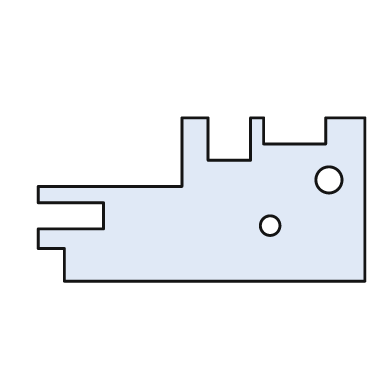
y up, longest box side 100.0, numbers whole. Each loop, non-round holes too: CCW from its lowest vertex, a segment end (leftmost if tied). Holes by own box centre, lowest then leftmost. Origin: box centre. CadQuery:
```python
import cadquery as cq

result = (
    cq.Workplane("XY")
    .moveTo(-42.0, -25.0)
    .lineTo(50.0, -25.0)
    .lineTo(50.0, 25.0)
    .lineTo(38.0, 25.0)
    .lineTo(38.0, 17.0)
    .lineTo(19.0, 17.0)
    .lineTo(19.0, 25.0)
    .lineTo(15.0, 25.0)
    .lineTo(15.0, 12.0)
    .lineTo(2.0, 12.0)
    .lineTo(2.0, 25.0)
    .lineTo(-6.0, 25.0)
    .lineTo(-6.0, 4.0)
    .lineTo(-50.0, 4.0)
    .lineTo(-50.0, -1.0)
    .lineTo(-30.0, -1.0)
    .lineTo(-30.0, -9.0)
    .lineTo(-50.0, -9.0)
    .lineTo(-50.0, -15.0)
    .lineTo(-42.0, -15.0)
    .close()
    .moveTo(21.0, -8.0)
    .circle(3.0)
    .moveTo(39.0, 6.0)
    .circle(4.0)
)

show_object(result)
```